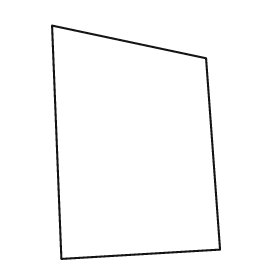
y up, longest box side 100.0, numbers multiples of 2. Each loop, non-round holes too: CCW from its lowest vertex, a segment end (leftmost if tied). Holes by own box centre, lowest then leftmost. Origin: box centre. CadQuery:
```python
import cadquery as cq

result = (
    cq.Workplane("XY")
    .moveTo(-32.0, -50.0)
    .lineTo(36.0, -46.0)
    .lineTo(30.0, 36.0)
    .lineTo(-36.0, 50.0)
    .close()
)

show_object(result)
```